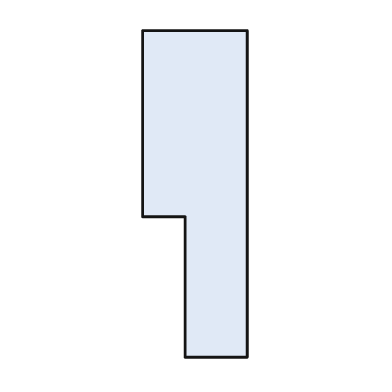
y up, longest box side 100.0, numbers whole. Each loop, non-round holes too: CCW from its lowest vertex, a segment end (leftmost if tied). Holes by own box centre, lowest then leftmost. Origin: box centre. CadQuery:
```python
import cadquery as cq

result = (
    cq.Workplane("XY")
    .moveTo(-3.0, -50.0)
    .lineTo(16.0, -50.0)
    .lineTo(16.0, 50.0)
    .lineTo(-16.0, 50.0)
    .lineTo(-16.0, -7.0)
    .lineTo(-3.0, -7.0)
    .close()
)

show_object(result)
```